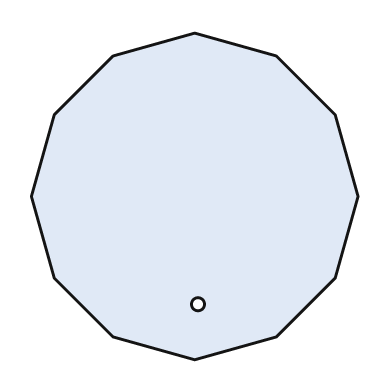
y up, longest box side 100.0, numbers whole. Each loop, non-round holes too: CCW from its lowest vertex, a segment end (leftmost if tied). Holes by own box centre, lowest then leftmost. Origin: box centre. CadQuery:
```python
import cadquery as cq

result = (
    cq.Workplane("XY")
    .moveTo(0.0, -50.0)
    .lineTo(25.0, -43.0)
    .lineTo(43.0, -25.0)
    .lineTo(50.0, 0.0)
    .lineTo(43.0, 25.0)
    .lineTo(25.0, 43.0)
    .lineTo(0.0, 50.0)
    .lineTo(-25.0, 43.0)
    .lineTo(-43.0, 25.0)
    .lineTo(-50.0, 0.0)
    .lineTo(-43.0, -25.0)
    .lineTo(-25.0, -43.0)
    .close()
    .moveTo(1.0, -33.0)
    .circle(2.0)
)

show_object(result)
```